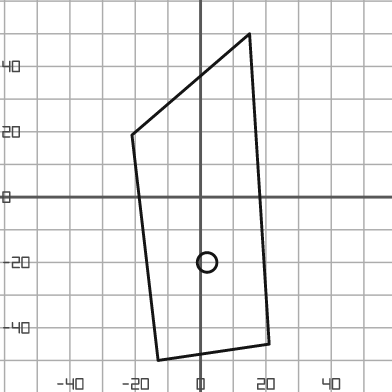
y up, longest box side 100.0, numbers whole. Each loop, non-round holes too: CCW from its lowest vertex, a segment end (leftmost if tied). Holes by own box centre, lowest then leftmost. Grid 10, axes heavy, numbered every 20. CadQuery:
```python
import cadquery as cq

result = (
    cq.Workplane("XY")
    .moveTo(-13.0, -50.0)
    .lineTo(21.0, -45.0)
    .lineTo(15.0, 50.0)
    .lineTo(-21.0, 19.0)
    .close()
    .moveTo(2.0, -20.0)
    .circle(3.0)
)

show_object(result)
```